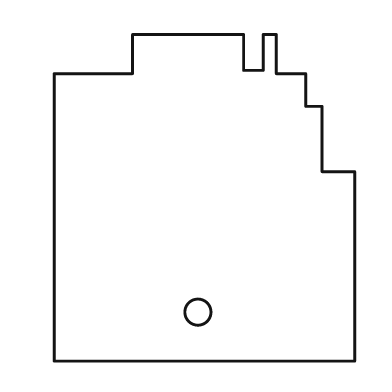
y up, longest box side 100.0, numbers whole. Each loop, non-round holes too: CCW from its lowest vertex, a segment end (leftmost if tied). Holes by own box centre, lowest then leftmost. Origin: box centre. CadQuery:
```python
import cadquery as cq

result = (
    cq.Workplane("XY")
    .moveTo(-46.0, -50.0)
    .lineTo(46.0, -50.0)
    .lineTo(46.0, 8.0)
    .lineTo(36.0, 8.0)
    .lineTo(36.0, 28.0)
    .lineTo(31.0, 28.0)
    .lineTo(31.0, 38.0)
    .lineTo(22.0, 38.0)
    .lineTo(22.0, 50.0)
    .lineTo(18.0, 50.0)
    .lineTo(18.0, 39.0)
    .lineTo(12.0, 39.0)
    .lineTo(12.0, 50.0)
    .lineTo(-22.0, 50.0)
    .lineTo(-22.0, 38.0)
    .lineTo(-46.0, 38.0)
    .close()
    .moveTo(-2.0, -35.0)
    .circle(4.0)
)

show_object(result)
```